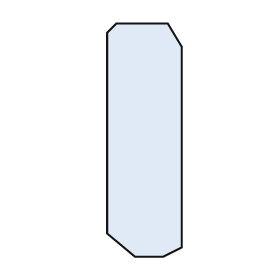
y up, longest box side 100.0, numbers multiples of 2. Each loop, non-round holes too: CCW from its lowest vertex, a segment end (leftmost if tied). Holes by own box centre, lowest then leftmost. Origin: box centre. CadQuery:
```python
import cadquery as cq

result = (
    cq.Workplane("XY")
    .moveTo(-4.0, -50.0)
    .lineTo(8.0, -50.0)
    .lineTo(16.0, -46.0)
    .lineTo(16.0, 40.0)
    .lineTo(10.0, 50.0)
    .lineTo(-12.0, 50.0)
    .lineTo(-16.0, 46.0)
    .lineTo(-16.0, -40.0)
    .close()
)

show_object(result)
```